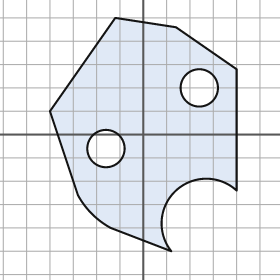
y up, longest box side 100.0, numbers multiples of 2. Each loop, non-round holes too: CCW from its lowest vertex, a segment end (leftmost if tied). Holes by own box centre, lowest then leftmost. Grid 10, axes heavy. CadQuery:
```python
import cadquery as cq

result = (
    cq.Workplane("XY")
    .moveTo(12.0, -50.0)
    .threePointArc((14.0, -24.0), (40.0, -24.0))
    .lineTo(40.0, 28.0)
    .lineTo(14.0, 46.0)
    .lineTo(-12.0, 50.0)
    .lineTo(-40.0, 10.0)
    .lineTo(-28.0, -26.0)
    .threePointArc((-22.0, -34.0), (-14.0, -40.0))
    .close()
    .moveTo(-16.0, -6.0)
    .circle(8.0)
    .moveTo(24.0, 20.0)
    .circle(8.0)
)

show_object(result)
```